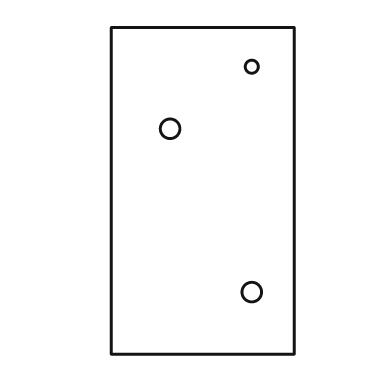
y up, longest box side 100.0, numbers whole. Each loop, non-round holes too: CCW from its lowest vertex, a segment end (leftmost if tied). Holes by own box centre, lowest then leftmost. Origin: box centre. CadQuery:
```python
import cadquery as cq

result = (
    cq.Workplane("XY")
    .moveTo(-28.0, -50.0)
    .lineTo(28.0, -50.0)
    .lineTo(28.0, 50.0)
    .lineTo(-28.0, 50.0)
    .close()
    .moveTo(15.0, -31.0)
    .circle(3.0)
    .moveTo(-10.0, 19.0)
    .circle(3.0)
    .moveTo(15.0, 38.0)
    .circle(2.0)
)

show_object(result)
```